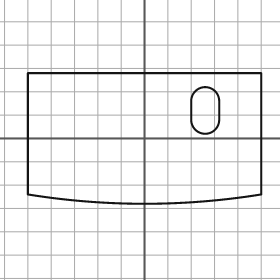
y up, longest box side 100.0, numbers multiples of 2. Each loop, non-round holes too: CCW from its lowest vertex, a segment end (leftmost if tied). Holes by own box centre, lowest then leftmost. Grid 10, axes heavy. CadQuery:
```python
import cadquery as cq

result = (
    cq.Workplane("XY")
    .moveTo(-50.0, -24.0)
    .threePointArc((0.0, -28.0), (50.0, -24.0))
    .lineTo(50.0, 28.0)
    .lineTo(-50.0, 28.0)
    .close()
    .moveTo(20.0, 8.0)
    .threePointArc((26.0, 2.0), (32.0, 8.0))
    .lineTo(32.0, 16.0)
    .threePointArc((26.0, 22.0), (20.0, 16.0))
    .close()
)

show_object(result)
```